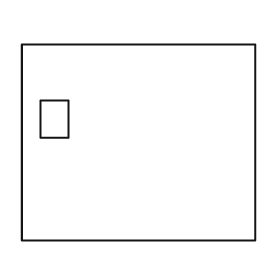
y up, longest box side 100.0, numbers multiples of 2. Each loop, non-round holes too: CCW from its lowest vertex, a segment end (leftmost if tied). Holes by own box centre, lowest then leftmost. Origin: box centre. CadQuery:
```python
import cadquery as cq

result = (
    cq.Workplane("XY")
    .moveTo(-50.0, -42.0)
    .lineTo(50.0, -42.0)
    .lineTo(50.0, 42.0)
    .lineTo(-50.0, 42.0)
    .close()
    .moveTo(-42.0, 2.0)
    .lineTo(-30.0, 2.0)
    .lineTo(-30.0, 18.0)
    .lineTo(-42.0, 18.0)
    .close()
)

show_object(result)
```